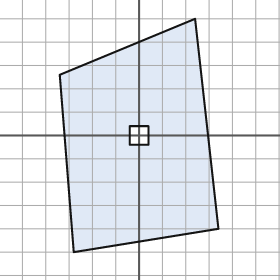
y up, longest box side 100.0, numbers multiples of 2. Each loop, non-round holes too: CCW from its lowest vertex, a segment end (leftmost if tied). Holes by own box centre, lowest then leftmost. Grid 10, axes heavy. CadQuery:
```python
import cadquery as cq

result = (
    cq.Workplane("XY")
    .moveTo(-28.0, -50.0)
    .lineTo(34.0, -40.0)
    .lineTo(24.0, 50.0)
    .lineTo(-34.0, 26.0)
    .close()
    .moveTo(-4.0, -4.0)
    .lineTo(4.0, -4.0)
    .lineTo(4.0, 4.0)
    .lineTo(-4.0, 4.0)
    .close()
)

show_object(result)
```